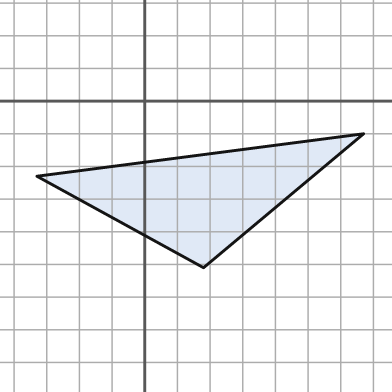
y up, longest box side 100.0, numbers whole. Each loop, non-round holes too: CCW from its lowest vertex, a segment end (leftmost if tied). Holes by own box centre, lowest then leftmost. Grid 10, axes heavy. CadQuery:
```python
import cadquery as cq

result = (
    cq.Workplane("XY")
    .moveTo(18.0, -51.0)
    .lineTo(67.0, -10.0)
    .lineTo(-33.0, -23.0)
    .close()
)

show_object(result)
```